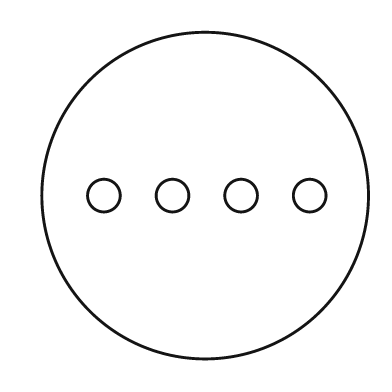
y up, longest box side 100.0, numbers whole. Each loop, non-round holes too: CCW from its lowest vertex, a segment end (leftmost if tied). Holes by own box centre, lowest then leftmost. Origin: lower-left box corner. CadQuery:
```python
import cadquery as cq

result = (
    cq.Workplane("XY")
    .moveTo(50.0, 50.0)
    .circle(50.0)
    .moveTo(19.0, 50.0)
    .circle(5.0)
    .moveTo(40.0, 50.0)
    .circle(5.0)
    .moveTo(61.0, 50.0)
    .circle(5.0)
    .moveTo(82.0, 50.0)
    .circle(5.0)
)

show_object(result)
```